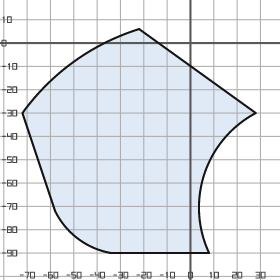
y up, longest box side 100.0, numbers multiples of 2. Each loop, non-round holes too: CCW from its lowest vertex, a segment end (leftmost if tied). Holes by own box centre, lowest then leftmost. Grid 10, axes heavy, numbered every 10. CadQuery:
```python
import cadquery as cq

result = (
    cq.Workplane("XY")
    .moveTo(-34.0, -90.0)
    .lineTo(8.0, -90.0)
    .threePointArc((6.0, -56.0), (28.0, -30.0))
    .lineTo(-22.0, 6.0)
    .threePointArc((-50.0, -8.0), (-72.0, -30.0))
    .lineTo(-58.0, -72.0)
    .threePointArc((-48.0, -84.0), (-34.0, -90.0))
    .close()
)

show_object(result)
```